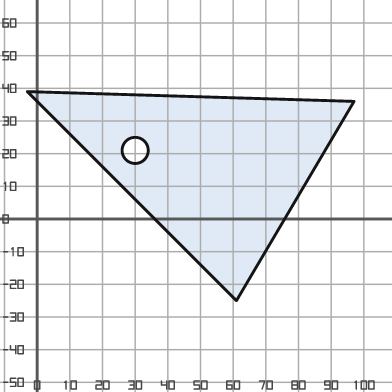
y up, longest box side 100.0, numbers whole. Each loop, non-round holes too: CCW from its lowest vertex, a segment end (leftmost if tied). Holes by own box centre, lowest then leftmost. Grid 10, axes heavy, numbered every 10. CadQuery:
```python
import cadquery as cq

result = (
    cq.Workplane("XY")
    .moveTo(61.0, -25.0)
    .lineTo(97.0, 36.0)
    .lineTo(-3.0, 39.0)
    .close()
    .moveTo(30.0, 21.0)
    .circle(4.0)
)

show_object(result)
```